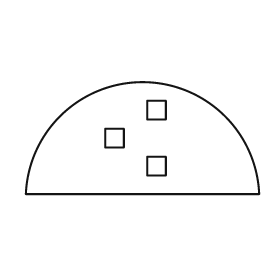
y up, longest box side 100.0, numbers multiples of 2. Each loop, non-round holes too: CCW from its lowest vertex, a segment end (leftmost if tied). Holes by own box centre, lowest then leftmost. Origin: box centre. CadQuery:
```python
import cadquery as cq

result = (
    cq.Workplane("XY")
    .moveTo(-50.0, -24.0)
    .lineTo(50.0, -24.0)
    .threePointArc((0.0, 24.0), (-50.0, -24.0))
    .close()
    .moveTo(2.0, -16.0)
    .lineTo(10.0, -16.0)
    .lineTo(10.0, -8.0)
    .lineTo(2.0, -8.0)
    .close()
    .moveTo(-16.0, -4.0)
    .lineTo(-8.0, -4.0)
    .lineTo(-8.0, 4.0)
    .lineTo(-16.0, 4.0)
    .close()
    .moveTo(2.0, 8.0)
    .lineTo(10.0, 8.0)
    .lineTo(10.0, 16.0)
    .lineTo(2.0, 16.0)
    .close()
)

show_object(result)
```